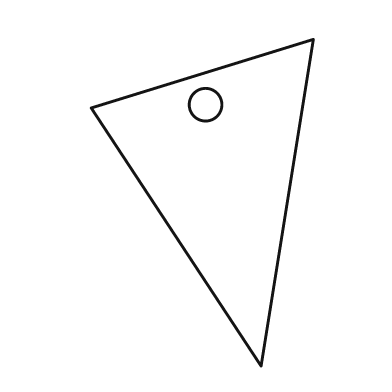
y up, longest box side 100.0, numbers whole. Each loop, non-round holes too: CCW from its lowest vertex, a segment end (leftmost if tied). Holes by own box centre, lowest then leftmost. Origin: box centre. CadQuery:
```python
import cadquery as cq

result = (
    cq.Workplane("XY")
    .moveTo(18.0, -50.0)
    .lineTo(34.0, 50.0)
    .lineTo(-34.0, 29.0)
    .close()
    .moveTo(1.0, 30.0)
    .circle(5.0)
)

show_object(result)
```